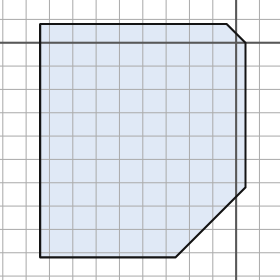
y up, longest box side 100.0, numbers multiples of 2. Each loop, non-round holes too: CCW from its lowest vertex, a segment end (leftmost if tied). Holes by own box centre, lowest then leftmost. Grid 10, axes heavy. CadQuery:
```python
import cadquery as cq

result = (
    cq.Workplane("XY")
    .moveTo(-84.0, -92.0)
    .lineTo(-26.0, -92.0)
    .lineTo(4.0, -62.0)
    .lineTo(4.0, 0.0)
    .lineTo(-4.0, 8.0)
    .lineTo(-84.0, 8.0)
    .close()
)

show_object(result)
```